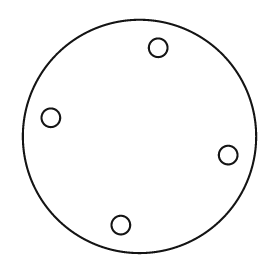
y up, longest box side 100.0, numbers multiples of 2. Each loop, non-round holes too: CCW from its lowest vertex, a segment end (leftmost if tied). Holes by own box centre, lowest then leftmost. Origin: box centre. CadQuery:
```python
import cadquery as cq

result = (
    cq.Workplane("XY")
    .moveTo(0.0, 0.0)
    .circle(50.0)
    .moveTo(-8.0, -38.0)
    .circle(4.0)
    .moveTo(38.0, -8.0)
    .circle(4.0)
    .moveTo(-38.0, 8.0)
    .circle(4.0)
    .moveTo(8.0, 38.0)
    .circle(4.0)
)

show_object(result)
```